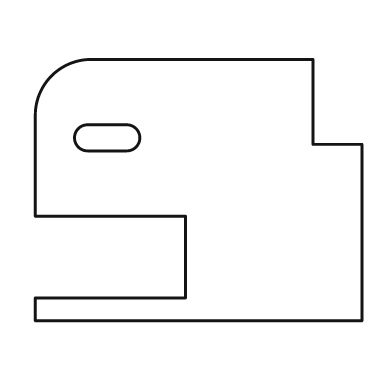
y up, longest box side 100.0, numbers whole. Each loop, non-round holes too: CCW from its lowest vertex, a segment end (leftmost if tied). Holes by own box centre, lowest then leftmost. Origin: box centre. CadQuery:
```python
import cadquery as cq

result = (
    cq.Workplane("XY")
    .moveTo(-50.0, -40.0)
    .lineTo(50.0, -40.0)
    .lineTo(50.0, 14.0)
    .lineTo(35.0, 14.0)
    .lineTo(35.0, 40.0)
    .lineTo(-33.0, 40.0)
    .threePointArc((-45.0, 35.0), (-50.0, 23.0))
    .lineTo(-50.0, -8.0)
    .lineTo(-4.0, -8.0)
    .lineTo(-4.0, -33.0)
    .lineTo(-50.0, -33.0)
    .close()
    .moveTo(-34.0, 12.0)
    .lineTo(-22.0, 12.0)
    .threePointArc((-18.0, 16.0), (-22.0, 20.0))
    .lineTo(-34.0, 20.0)
    .threePointArc((-38.0, 16.0), (-34.0, 12.0))
    .close()
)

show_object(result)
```